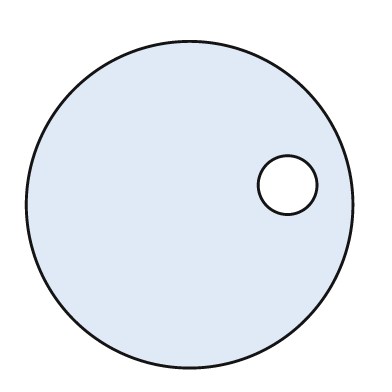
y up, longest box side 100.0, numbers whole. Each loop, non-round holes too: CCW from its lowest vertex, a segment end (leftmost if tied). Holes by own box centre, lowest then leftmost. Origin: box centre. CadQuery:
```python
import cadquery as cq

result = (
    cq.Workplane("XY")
    .moveTo(0.0, 0.0)
    .circle(50.0)
    .moveTo(30.0, 6.0)
    .circle(9.0)
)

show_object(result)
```